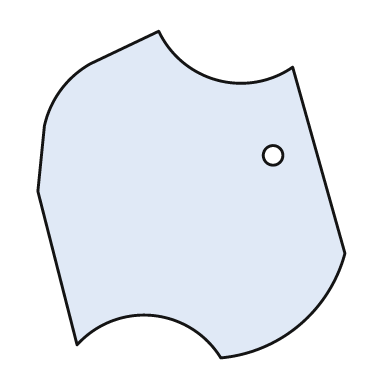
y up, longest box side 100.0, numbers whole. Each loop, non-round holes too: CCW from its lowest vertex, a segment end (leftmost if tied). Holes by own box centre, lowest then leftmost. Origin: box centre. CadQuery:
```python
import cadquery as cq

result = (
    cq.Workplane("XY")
    .moveTo(9.0, -50.0)
    .threePointArc((33.0, -40.0), (47.0, -18.0))
    .lineTo(31.0, 39.0)
    .threePointArc((8.0, 35.0), (-10.0, 50.0))
    .lineTo(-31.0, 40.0)
    .threePointArc((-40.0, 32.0), (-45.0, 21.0))
    .lineTo(-47.0, 1.0)
    .lineTo(-35.0, -46.0)
    .threePointArc((-12.0, -37.0), (9.0, -50.0))
    .close()
    .moveTo(25.0, 12.0)
    .circle(3.0)
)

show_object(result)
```